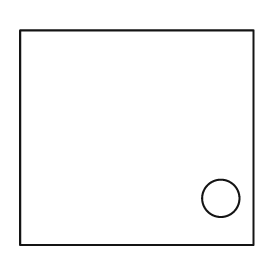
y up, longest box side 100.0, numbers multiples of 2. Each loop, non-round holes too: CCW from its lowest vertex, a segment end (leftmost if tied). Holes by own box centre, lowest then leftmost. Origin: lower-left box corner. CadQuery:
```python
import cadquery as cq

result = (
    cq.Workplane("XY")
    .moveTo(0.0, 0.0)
    .lineTo(100.0, 0.0)
    .lineTo(100.0, 92.0)
    .lineTo(0.0, 92.0)
    .close()
    .moveTo(86.0, 20.0)
    .circle(8.0)
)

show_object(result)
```